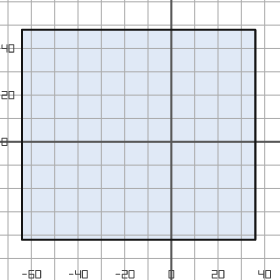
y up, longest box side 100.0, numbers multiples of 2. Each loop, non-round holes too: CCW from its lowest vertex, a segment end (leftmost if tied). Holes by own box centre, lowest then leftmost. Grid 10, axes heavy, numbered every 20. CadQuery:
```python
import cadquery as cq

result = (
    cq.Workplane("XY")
    .moveTo(-64.0, -42.0)
    .lineTo(36.0, -42.0)
    .lineTo(36.0, 48.0)
    .lineTo(-64.0, 48.0)
    .close()
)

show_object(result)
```